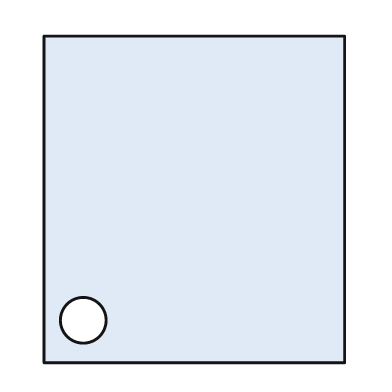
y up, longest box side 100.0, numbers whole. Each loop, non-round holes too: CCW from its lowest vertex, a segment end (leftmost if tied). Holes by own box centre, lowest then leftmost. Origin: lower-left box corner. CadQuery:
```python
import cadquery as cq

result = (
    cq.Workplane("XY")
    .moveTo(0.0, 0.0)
    .lineTo(92.0, 0.0)
    .lineTo(92.0, 100.0)
    .lineTo(0.0, 100.0)
    .close()
    .moveTo(12.0, 13.0)
    .circle(7.0)
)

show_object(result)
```